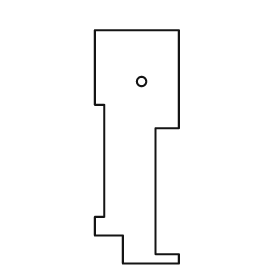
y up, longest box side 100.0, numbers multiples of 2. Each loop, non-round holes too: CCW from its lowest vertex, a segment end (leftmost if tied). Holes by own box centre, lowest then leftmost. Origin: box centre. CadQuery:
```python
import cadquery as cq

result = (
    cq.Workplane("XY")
    .moveTo(-6.0, -50.0)
    .lineTo(18.0, -50.0)
    .lineTo(18.0, -46.0)
    .lineTo(8.0, -46.0)
    .lineTo(8.0, 8.0)
    .lineTo(18.0, 8.0)
    .lineTo(18.0, 50.0)
    .lineTo(-18.0, 50.0)
    .lineTo(-18.0, 18.0)
    .lineTo(-14.0, 18.0)
    .lineTo(-14.0, -30.0)
    .lineTo(-18.0, -30.0)
    .lineTo(-18.0, -38.0)
    .lineTo(-6.0, -38.0)
    .close()
    .moveTo(2.0, 28.0)
    .circle(2.0)
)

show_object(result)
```